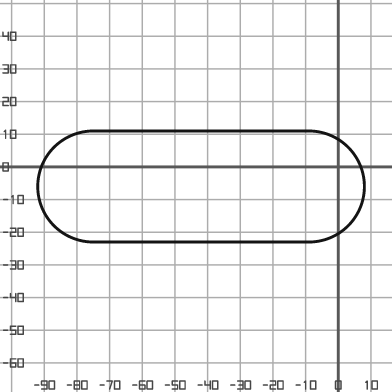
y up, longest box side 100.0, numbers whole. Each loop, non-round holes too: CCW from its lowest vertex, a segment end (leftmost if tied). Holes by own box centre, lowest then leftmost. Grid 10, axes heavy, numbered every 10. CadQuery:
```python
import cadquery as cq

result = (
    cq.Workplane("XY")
    .moveTo(-75.0, -23.0)
    .lineTo(-9.0, -23.0)
    .threePointArc((8.0, -6.0), (-9.0, 11.0))
    .lineTo(-75.0, 11.0)
    .threePointArc((-92.0, -6.0), (-75.0, -23.0))
    .close()
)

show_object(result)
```